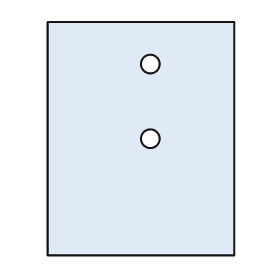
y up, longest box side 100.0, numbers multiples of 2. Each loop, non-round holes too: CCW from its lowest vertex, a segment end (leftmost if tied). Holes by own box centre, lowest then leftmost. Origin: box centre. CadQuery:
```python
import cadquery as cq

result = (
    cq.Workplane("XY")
    .moveTo(-40.0, -50.0)
    .lineTo(40.0, -50.0)
    .lineTo(40.0, 50.0)
    .lineTo(-40.0, 50.0)
    .close()
    .moveTo(4.0, 0.0)
    .circle(4.0)
    .moveTo(4.0, 32.0)
    .circle(4.0)
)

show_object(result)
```